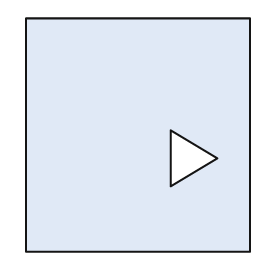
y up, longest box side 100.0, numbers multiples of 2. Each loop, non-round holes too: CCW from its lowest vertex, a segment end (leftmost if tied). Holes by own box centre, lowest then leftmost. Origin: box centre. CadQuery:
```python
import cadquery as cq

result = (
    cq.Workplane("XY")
    .moveTo(-48.0, -50.0)
    .lineTo(48.0, -50.0)
    .lineTo(48.0, 50.0)
    .lineTo(-48.0, 50.0)
    .close()
    .moveTo(14.0, -22.0)
    .lineTo(34.0, -10.0)
    .lineTo(14.0, 2.0)
    .close()
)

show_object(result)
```